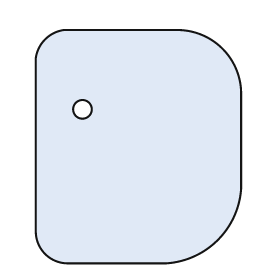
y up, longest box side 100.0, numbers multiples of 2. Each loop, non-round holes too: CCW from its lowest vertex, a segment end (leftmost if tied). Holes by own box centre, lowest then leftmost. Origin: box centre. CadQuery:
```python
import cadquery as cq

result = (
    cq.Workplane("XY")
    .moveTo(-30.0, -50.0)
    .lineTo(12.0, -50.0)
    .threePointArc((34.0, -40.0), (44.0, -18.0))
    .lineTo(44.0, 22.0)
    .threePointArc((36.0, 42.0), (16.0, 50.0))
    .lineTo(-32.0, 50.0)
    .threePointArc((-40.0, 46.0), (-44.0, 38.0))
    .lineTo(-44.0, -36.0)
    .threePointArc((-40.0, -46.0), (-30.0, -50.0))
    .close()
    .moveTo(-24.0, 16.0)
    .circle(4.0)
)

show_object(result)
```